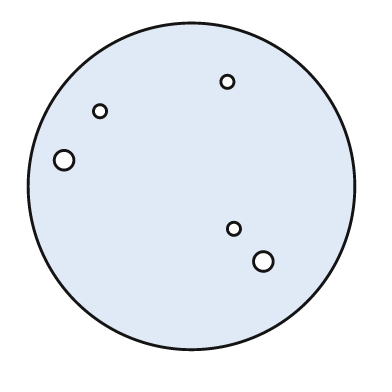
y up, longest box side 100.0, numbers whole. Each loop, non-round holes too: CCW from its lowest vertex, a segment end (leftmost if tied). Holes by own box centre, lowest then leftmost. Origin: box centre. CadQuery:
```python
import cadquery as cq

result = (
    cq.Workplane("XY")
    .moveTo(0.0, 0.0)
    .circle(50.0)
    .moveTo(22.0, -23.0)
    .circle(3.0)
    .moveTo(13.0, -13.0)
    .circle(2.0)
    .moveTo(-39.0, 8.0)
    .circle(3.0)
    .moveTo(-28.0, 23.0)
    .circle(2.0)
    .moveTo(11.0, 32.0)
    .circle(2.0)
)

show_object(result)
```